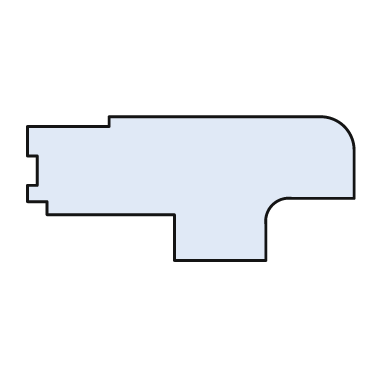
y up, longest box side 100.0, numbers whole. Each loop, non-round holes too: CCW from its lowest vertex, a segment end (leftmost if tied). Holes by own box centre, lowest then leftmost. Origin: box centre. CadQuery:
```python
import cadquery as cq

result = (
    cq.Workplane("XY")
    .moveTo(-5.0, -22.0)
    .lineTo(23.0, -22.0)
    .lineTo(23.0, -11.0)
    .threePointArc((25.0, -5.0), (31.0, -3.0))
    .lineTo(50.0, -3.0)
    .lineTo(50.0, 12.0)
    .threePointArc((47.0, 19.0), (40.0, 22.0))
    .lineTo(-25.0, 22.0)
    .lineTo(-25.0, 19.0)
    .lineTo(-50.0, 19.0)
    .lineTo(-50.0, 10.0)
    .lineTo(-47.0, 10.0)
    .lineTo(-47.0, 1.0)
    .lineTo(-50.0, 1.0)
    .lineTo(-50.0, -4.0)
    .lineTo(-44.0, -4.0)
    .lineTo(-44.0, -8.0)
    .lineTo(-5.0, -8.0)
    .close()
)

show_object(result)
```